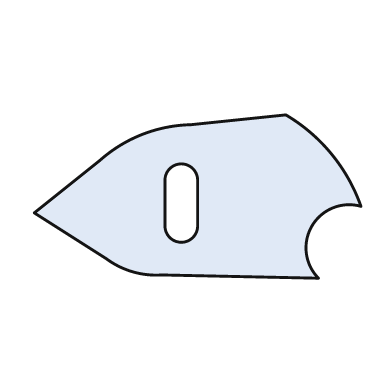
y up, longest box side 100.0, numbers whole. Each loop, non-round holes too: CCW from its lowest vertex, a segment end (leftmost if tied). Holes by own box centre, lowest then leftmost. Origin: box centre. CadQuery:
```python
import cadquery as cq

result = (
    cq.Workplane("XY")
    .moveTo(37.0, -25.0)
    .threePointArc((35.0, -9.0), (50.0, -3.0))
    .threePointArc((41.0, 13.0), (27.0, 25.0))
    .lineTo(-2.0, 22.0)
    .threePointArc((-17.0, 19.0), (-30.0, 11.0))
    .lineTo(-50.0, -5.0)
    .lineTo(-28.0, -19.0)
    .threePointArc((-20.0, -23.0), (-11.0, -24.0))
    .close()
    .moveTo(-10.0, -9.0)
    .threePointArc((-5.0, -14.0), (0.0, -9.0))
    .lineTo(0.0, 5.0)
    .threePointArc((-5.0, 10.0), (-10.0, 5.0))
    .close()
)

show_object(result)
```